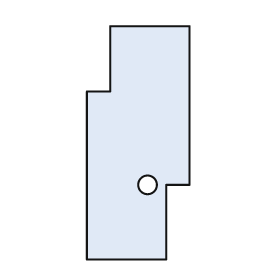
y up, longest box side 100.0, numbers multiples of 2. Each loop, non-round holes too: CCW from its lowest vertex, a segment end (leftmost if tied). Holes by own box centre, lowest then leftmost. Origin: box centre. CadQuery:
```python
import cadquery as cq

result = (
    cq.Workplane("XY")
    .moveTo(-22.0, -50.0)
    .lineTo(12.0, -50.0)
    .lineTo(12.0, -18.0)
    .lineTo(22.0, -18.0)
    .lineTo(22.0, 50.0)
    .lineTo(-12.0, 50.0)
    .lineTo(-12.0, 22.0)
    .lineTo(-22.0, 22.0)
    .close()
    .moveTo(4.0, -18.0)
    .circle(4.0)
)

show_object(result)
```